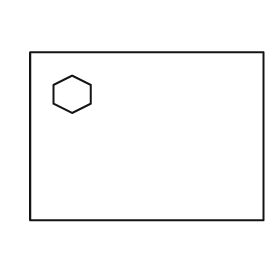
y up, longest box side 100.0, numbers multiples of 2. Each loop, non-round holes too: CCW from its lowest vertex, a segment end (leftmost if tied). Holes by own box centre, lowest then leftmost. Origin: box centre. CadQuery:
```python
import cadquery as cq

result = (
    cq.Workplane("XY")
    .moveTo(-50.0, -36.0)
    .lineTo(50.0, -36.0)
    .lineTo(50.0, 36.0)
    .lineTo(-50.0, 36.0)
    .close()
    .moveTo(-32.0, 10.0)
    .lineTo(-24.0, 14.0)
    .lineTo(-24.0, 22.0)
    .lineTo(-32.0, 26.0)
    .lineTo(-40.0, 22.0)
    .lineTo(-40.0, 14.0)
    .close()
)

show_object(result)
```